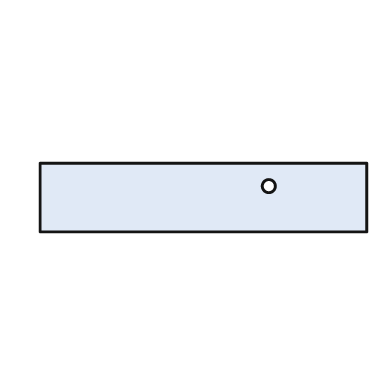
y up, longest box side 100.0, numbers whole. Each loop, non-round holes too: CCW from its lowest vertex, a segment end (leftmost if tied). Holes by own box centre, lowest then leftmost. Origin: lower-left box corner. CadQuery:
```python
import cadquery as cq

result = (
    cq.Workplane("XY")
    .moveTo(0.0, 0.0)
    .lineTo(100.0, 0.0)
    .lineTo(100.0, 21.0)
    .lineTo(0.0, 21.0)
    .close()
    .moveTo(70.0, 14.0)
    .circle(2.0)
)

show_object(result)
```